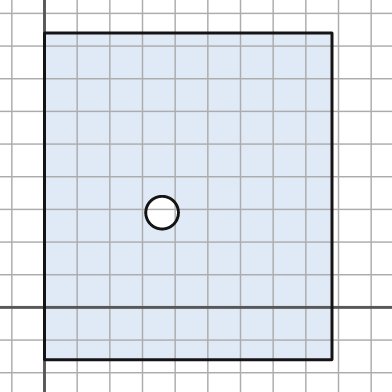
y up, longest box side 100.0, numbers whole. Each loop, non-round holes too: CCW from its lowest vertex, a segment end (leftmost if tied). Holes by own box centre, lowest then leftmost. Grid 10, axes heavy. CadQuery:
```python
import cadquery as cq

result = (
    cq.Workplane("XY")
    .moveTo(0.0, -16.0)
    .lineTo(88.0, -16.0)
    .lineTo(88.0, 84.0)
    .lineTo(0.0, 84.0)
    .close()
    .moveTo(36.0, 29.0)
    .circle(5.0)
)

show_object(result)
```